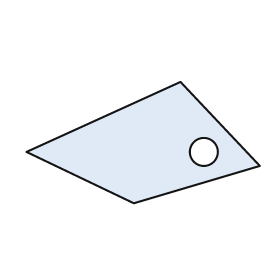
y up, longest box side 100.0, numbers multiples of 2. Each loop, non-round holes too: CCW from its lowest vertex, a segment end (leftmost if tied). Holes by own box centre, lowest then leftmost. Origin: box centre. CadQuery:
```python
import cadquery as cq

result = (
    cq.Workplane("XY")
    .moveTo(-4.0, -26.0)
    .lineTo(50.0, -10.0)
    .lineTo(16.0, 26.0)
    .lineTo(-50.0, -4.0)
    .close()
    .moveTo(26.0, -4.0)
    .circle(6.0)
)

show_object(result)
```